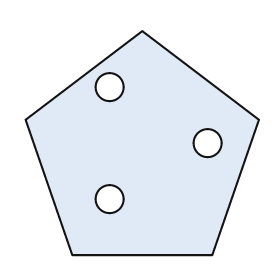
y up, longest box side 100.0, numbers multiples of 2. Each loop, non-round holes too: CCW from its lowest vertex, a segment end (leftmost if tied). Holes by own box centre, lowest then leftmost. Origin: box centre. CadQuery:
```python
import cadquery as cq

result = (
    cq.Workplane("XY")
    .moveTo(-30.0, -48.0)
    .lineTo(30.0, -48.0)
    .lineTo(50.0, 10.0)
    .lineTo(0.0, 48.0)
    .lineTo(-50.0, 10.0)
    .close()
    .moveTo(-14.0, -24.0)
    .circle(6.0)
    .moveTo(28.0, 0.0)
    .circle(6.0)
    .moveTo(-14.0, 24.0)
    .circle(6.0)
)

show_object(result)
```